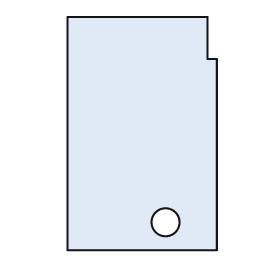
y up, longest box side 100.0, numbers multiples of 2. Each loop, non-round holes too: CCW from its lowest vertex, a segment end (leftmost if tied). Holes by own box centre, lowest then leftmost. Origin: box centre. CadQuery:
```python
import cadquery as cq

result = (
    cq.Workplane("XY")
    .moveTo(-32.0, -50.0)
    .lineTo(32.0, -50.0)
    .lineTo(32.0, 32.0)
    .lineTo(28.0, 32.0)
    .lineTo(28.0, 50.0)
    .lineTo(-32.0, 50.0)
    .close()
    .moveTo(10.0, -38.0)
    .circle(6.0)
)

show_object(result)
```